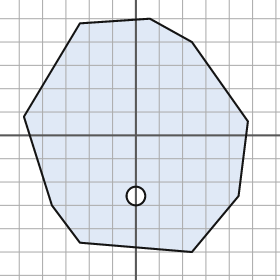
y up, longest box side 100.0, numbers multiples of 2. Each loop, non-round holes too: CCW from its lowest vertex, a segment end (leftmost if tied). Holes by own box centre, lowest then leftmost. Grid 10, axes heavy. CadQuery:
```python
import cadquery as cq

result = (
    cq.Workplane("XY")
    .moveTo(24.0, -50.0)
    .lineTo(44.0, -26.0)
    .lineTo(48.0, 6.0)
    .lineTo(24.0, 40.0)
    .lineTo(6.0, 50.0)
    .lineTo(-24.0, 48.0)
    .lineTo(-48.0, 8.0)
    .lineTo(-36.0, -30.0)
    .lineTo(-24.0, -46.0)
    .close()
    .moveTo(0.0, -26.0)
    .circle(4.0)
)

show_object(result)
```